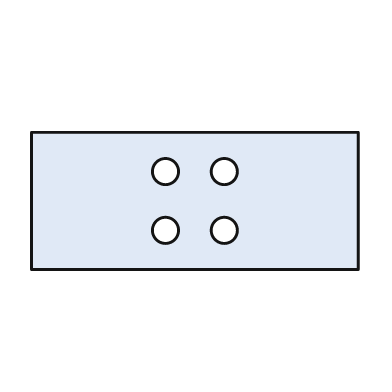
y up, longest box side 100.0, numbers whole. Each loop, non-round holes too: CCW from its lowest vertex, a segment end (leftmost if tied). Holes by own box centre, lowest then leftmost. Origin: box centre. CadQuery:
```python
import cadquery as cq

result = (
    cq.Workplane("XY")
    .moveTo(-50.0, -21.0)
    .lineTo(50.0, -21.0)
    .lineTo(50.0, 21.0)
    .lineTo(-50.0, 21.0)
    .close()
    .moveTo(-9.0, -9.0)
    .circle(4.0)
    .moveTo(9.0, -9.0)
    .circle(4.0)
    .moveTo(-9.0, 9.0)
    .circle(4.0)
    .moveTo(9.0, 9.0)
    .circle(4.0)
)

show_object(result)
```